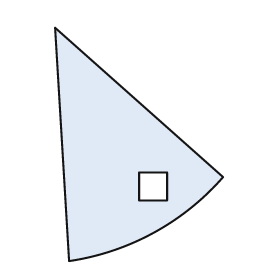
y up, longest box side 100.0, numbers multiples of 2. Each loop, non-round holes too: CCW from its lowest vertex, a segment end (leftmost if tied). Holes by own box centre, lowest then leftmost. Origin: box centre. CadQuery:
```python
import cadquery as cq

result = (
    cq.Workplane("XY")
    .moveTo(-30.0, -50.0)
    .threePointArc((6.0, -38.0), (36.0, -14.0))
    .lineTo(-36.0, 50.0)
    .close()
    .moveTo(0.0, -24.0)
    .lineTo(12.0, -24.0)
    .lineTo(12.0, -12.0)
    .lineTo(0.0, -12.0)
    .close()
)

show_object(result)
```